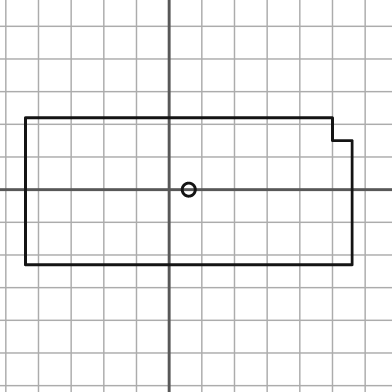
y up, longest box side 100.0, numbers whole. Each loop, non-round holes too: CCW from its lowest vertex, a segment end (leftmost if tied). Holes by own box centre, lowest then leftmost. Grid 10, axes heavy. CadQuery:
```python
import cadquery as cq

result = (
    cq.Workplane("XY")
    .moveTo(-44.0, -23.0)
    .lineTo(56.0, -23.0)
    .lineTo(56.0, 15.0)
    .lineTo(50.0, 15.0)
    .lineTo(50.0, 22.0)
    .lineTo(-44.0, 22.0)
    .close()
    .moveTo(6.0, 0.0)
    .circle(2.0)
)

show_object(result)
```